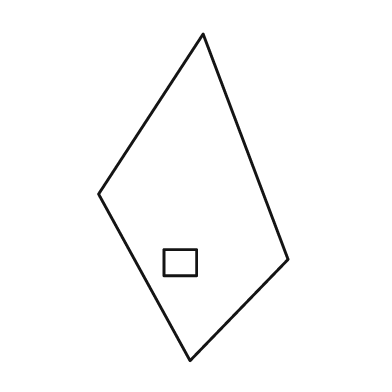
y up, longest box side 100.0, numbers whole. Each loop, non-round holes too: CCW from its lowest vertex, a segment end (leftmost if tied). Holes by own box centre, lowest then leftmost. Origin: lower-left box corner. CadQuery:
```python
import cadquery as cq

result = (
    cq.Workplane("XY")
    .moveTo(28.0, 0.0)
    .lineTo(58.0, 31.0)
    .lineTo(32.0, 100.0)
    .lineTo(0.0, 51.0)
    .close()
    .moveTo(20.0, 26.0)
    .lineTo(30.0, 26.0)
    .lineTo(30.0, 34.0)
    .lineTo(20.0, 34.0)
    .close()
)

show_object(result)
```